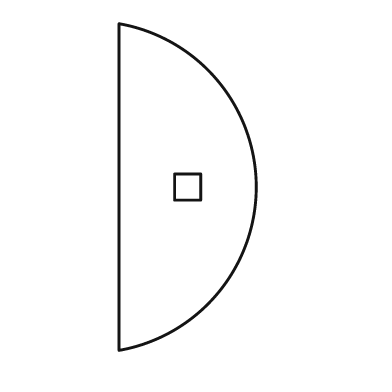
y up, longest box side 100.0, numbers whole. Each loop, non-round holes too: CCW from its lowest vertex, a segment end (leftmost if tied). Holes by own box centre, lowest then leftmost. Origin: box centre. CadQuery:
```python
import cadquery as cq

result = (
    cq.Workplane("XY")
    .moveTo(-21.0, -50.0)
    .threePointArc((21.0, 0.0), (-21.0, 50.0))
    .close()
    .moveTo(-4.0, -4.0)
    .lineTo(4.0, -4.0)
    .lineTo(4.0, 4.0)
    .lineTo(-4.0, 4.0)
    .close()
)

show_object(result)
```